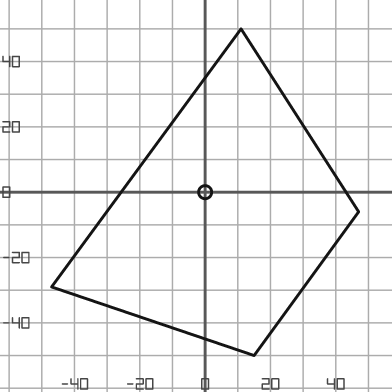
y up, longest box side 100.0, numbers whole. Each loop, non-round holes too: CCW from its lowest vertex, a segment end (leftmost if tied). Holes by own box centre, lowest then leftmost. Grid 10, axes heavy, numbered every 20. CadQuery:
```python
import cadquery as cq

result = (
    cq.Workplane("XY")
    .moveTo(15.0, -50.0)
    .lineTo(47.0, -6.0)
    .lineTo(11.0, 50.0)
    .lineTo(-47.0, -29.0)
    .close()
    .moveTo(0.0, 0.0)
    .circle(2.0)
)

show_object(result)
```